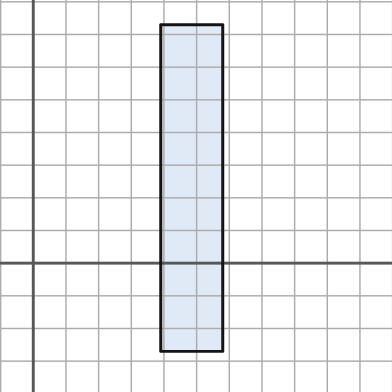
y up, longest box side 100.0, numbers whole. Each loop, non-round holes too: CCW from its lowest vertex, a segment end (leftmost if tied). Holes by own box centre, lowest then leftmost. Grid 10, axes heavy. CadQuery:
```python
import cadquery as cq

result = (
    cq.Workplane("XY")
    .moveTo(39.0, -27.0)
    .lineTo(58.0, -27.0)
    .lineTo(58.0, 73.0)
    .lineTo(39.0, 73.0)
    .close()
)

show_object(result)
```